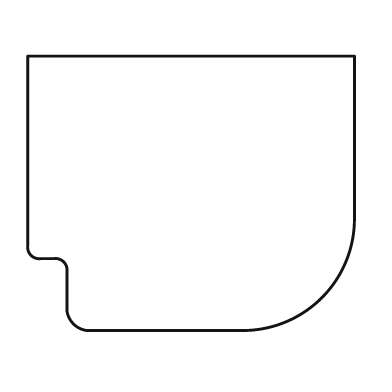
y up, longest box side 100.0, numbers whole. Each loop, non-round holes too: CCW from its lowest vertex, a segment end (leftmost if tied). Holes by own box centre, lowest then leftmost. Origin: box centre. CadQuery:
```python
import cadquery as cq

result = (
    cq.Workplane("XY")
    .moveTo(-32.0, -42.0)
    .lineTo(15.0, -42.0)
    .threePointArc((40.0, -32.0), (50.0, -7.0))
    .lineTo(50.0, 42.0)
    .lineTo(-50.0, 42.0)
    .lineTo(-50.0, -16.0)
    .threePointArc((-49.0, -19.0), (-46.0, -20.0))
    .lineTo(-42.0, -20.0)
    .threePointArc((-39.0, -21.0), (-38.0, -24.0))
    .lineTo(-38.0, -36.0)
    .threePointArc((-36.0, -40.0), (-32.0, -42.0))
    .close()
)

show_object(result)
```